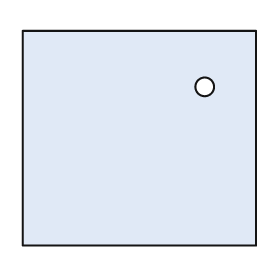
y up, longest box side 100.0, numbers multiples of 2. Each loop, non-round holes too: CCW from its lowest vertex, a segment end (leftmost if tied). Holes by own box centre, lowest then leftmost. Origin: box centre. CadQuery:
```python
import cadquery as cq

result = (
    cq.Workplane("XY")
    .moveTo(-50.0, -46.0)
    .lineTo(50.0, -46.0)
    .lineTo(50.0, 46.0)
    .lineTo(-50.0, 46.0)
    .close()
    .moveTo(28.0, 22.0)
    .circle(4.0)
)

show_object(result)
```